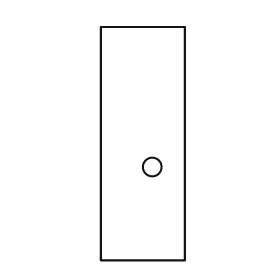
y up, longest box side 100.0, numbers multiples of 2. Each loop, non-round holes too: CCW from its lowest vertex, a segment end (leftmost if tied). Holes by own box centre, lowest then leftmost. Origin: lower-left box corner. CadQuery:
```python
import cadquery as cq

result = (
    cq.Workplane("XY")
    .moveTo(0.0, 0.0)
    .lineTo(36.0, 0.0)
    .lineTo(36.0, 100.0)
    .lineTo(0.0, 100.0)
    .close()
    .moveTo(22.0, 40.0)
    .circle(4.0)
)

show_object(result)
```